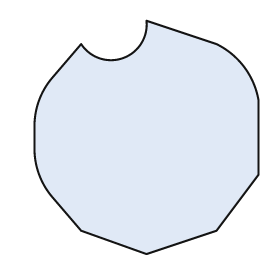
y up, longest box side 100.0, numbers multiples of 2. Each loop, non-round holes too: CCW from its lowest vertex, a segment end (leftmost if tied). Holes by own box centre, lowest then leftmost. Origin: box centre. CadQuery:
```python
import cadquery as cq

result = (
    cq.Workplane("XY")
    .moveTo(0.0, -50.0)
    .lineTo(30.0, -40.0)
    .lineTo(48.0, -16.0)
    .lineTo(48.0, 16.0)
    .threePointArc((42.0, 30.0), (30.0, 40.0))
    .lineTo(0.0, 50.0)
    .threePointArc((-10.0, 34.0), (-28.0, 40.0))
    .lineTo(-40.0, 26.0)
    .threePointArc((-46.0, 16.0), (-48.0, 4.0))
    .lineTo(-48.0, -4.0)
    .threePointArc((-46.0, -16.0), (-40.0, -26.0))
    .lineTo(-28.0, -40.0)
    .close()
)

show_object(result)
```